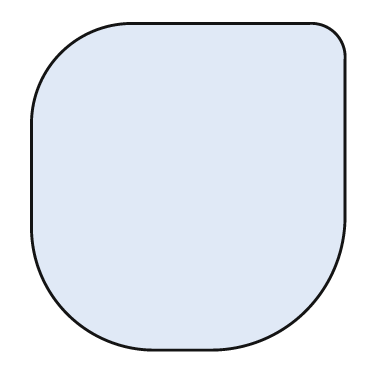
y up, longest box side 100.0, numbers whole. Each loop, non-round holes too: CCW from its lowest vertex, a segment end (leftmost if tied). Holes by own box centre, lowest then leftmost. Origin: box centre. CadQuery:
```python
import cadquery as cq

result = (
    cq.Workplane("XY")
    .moveTo(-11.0, -50.0)
    .lineTo(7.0, -50.0)
    .threePointArc((36.0, -38.0), (48.0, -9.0))
    .lineTo(48.0, 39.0)
    .threePointArc((45.0, 47.0), (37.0, 50.0))
    .lineTo(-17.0, 50.0)
    .threePointArc((-39.0, 41.0), (-48.0, 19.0))
    .lineTo(-48.0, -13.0)
    .threePointArc((-37.0, -39.0), (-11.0, -50.0))
    .close()
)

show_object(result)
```